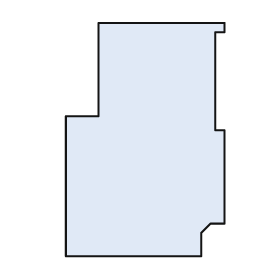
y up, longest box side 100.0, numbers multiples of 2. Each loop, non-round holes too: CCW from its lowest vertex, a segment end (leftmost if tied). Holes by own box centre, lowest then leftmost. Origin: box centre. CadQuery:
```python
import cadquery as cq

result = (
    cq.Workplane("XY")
    .moveTo(-34.0, -50.0)
    .lineTo(24.0, -50.0)
    .lineTo(24.0, -40.0)
    .lineTo(28.0, -36.0)
    .lineTo(34.0, -36.0)
    .lineTo(34.0, 4.0)
    .lineTo(30.0, 4.0)
    .lineTo(30.0, 46.0)
    .lineTo(34.0, 46.0)
    .lineTo(34.0, 50.0)
    .lineTo(-20.0, 50.0)
    .lineTo(-20.0, 10.0)
    .lineTo(-34.0, 10.0)
    .close()
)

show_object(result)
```